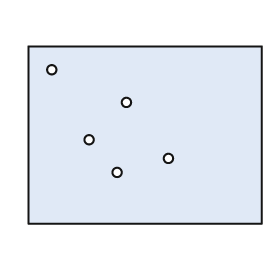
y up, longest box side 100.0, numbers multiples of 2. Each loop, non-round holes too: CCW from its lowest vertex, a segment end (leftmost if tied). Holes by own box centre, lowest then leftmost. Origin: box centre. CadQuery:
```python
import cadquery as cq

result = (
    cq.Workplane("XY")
    .moveTo(-50.0, -38.0)
    .lineTo(50.0, -38.0)
    .lineTo(50.0, 38.0)
    .lineTo(-50.0, 38.0)
    .close()
    .moveTo(-12.0, -16.0)
    .circle(2.0)
    .moveTo(10.0, -10.0)
    .circle(2.0)
    .moveTo(-24.0, -2.0)
    .circle(2.0)
    .moveTo(-8.0, 14.0)
    .circle(2.0)
    .moveTo(-40.0, 28.0)
    .circle(2.0)
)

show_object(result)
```